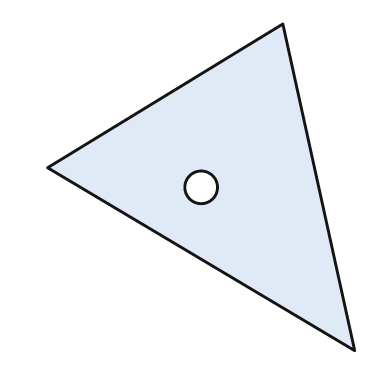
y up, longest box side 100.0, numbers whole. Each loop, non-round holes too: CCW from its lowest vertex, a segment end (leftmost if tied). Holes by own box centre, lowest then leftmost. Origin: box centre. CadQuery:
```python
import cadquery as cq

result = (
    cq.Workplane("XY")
    .moveTo(47.0, -50.0)
    .lineTo(25.0, 50.0)
    .lineTo(-47.0, 6.0)
    .close()
    .moveTo(0.0, 0.0)
    .circle(5.0)
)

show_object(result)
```